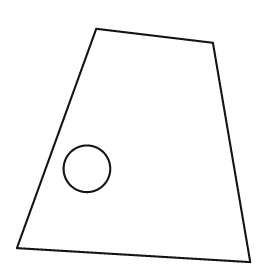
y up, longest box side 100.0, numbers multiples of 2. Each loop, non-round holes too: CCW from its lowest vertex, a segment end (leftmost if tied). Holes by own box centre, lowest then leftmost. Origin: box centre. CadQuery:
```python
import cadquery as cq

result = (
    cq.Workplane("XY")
    .moveTo(50.0, -50.0)
    .lineTo(34.0, 44.0)
    .lineTo(-16.0, 50.0)
    .lineTo(-50.0, -44.0)
    .close()
    .moveTo(-20.0, -10.0)
    .circle(10.0)
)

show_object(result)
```